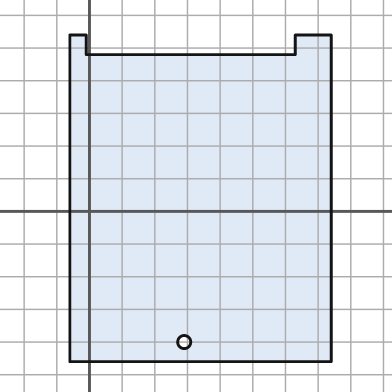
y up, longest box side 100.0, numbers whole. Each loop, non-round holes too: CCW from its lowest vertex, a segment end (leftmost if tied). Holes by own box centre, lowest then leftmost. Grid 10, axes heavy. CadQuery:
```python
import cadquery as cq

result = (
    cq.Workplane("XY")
    .moveTo(-6.0, -46.0)
    .lineTo(74.0, -46.0)
    .lineTo(74.0, 54.0)
    .lineTo(63.0, 54.0)
    .lineTo(63.0, 48.0)
    .lineTo(-1.0, 48.0)
    .lineTo(-1.0, 54.0)
    .lineTo(-6.0, 54.0)
    .close()
    .moveTo(29.0, -40.0)
    .circle(2.0)
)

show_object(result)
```